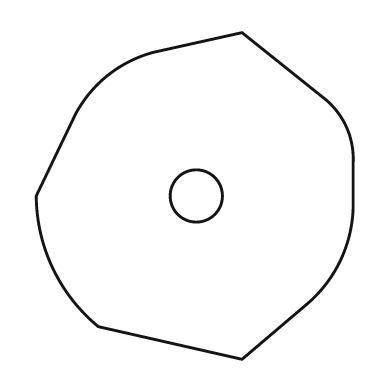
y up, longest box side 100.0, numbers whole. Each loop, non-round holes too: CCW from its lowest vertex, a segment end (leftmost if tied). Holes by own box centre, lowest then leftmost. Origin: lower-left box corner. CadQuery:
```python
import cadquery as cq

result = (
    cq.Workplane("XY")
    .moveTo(63.0, 0.0)
    .lineTo(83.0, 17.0)
    .threePointArc((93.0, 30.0), (97.0, 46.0))
    .lineTo(97.0, 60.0)
    .threePointArc((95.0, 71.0), (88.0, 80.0))
    .lineTo(63.0, 100.0)
    .lineTo(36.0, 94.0)
    .threePointArc((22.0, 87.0), (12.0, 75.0))
    .lineTo(0.0, 50.0)
    .threePointArc((5.0, 28.0), (19.0, 10.0))
    .close()
    .moveTo(49.0, 50.0)
    .circle(8.0)
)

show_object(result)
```